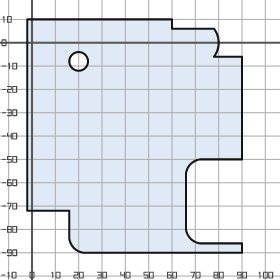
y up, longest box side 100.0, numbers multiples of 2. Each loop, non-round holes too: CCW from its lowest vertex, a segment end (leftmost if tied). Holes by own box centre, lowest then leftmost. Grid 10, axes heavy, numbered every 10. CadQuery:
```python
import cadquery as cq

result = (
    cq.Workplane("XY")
    .moveTo(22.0, -90.0)
    .lineTo(90.0, -90.0)
    .lineTo(90.0, -86.0)
    .lineTo(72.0, -86.0)
    .threePointArc((68.0, -84.0), (66.0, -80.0))
    .lineTo(66.0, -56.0)
    .threePointArc((68.0, -52.0), (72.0, -50.0))
    .lineTo(90.0, -50.0)
    .lineTo(90.0, -6.0)
    .lineTo(78.0, -6.0)
    .threePointArc((80.0, 0.0), (78.0, 6.0))
    .lineTo(60.0, 6.0)
    .lineTo(60.0, 10.0)
    .lineTo(-2.0, 10.0)
    .lineTo(-2.0, -72.0)
    .lineTo(16.0, -72.0)
    .lineTo(16.0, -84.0)
    .threePointArc((18.0, -88.0), (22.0, -90.0))
    .close()
    .moveTo(20.0, -8.0)
    .circle(4.0)
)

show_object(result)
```